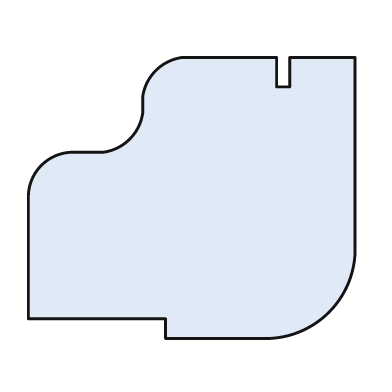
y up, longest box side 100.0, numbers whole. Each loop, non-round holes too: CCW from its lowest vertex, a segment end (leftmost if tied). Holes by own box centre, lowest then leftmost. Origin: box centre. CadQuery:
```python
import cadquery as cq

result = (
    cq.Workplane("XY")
    .moveTo(-8.0, -43.0)
    .lineTo(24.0, -43.0)
    .threePointArc((42.0, -35.0), (50.0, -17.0))
    .lineTo(50.0, 43.0)
    .lineTo(30.0, 43.0)
    .lineTo(30.0, 34.0)
    .lineTo(26.0, 34.0)
    .lineTo(26.0, 43.0)
    .lineTo(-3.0, 43.0)
    .threePointArc((-11.0, 39.0), (-15.0, 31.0))
    .lineTo(-15.0, 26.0)
    .threePointArc((-19.0, 18.0), (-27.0, 14.0))
    .lineTo(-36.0, 14.0)
    .threePointArc((-46.0, 10.0), (-50.0, 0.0))
    .lineTo(-50.0, -37.0)
    .lineTo(-8.0, -37.0)
    .close()
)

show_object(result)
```